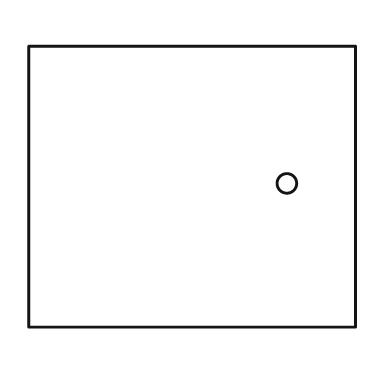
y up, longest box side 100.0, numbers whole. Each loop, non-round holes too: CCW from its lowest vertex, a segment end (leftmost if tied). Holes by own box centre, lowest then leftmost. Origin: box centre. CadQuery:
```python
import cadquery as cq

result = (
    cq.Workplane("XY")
    .moveTo(-50.0, -43.0)
    .lineTo(50.0, -43.0)
    .lineTo(50.0, 43.0)
    .lineTo(-50.0, 43.0)
    .close()
    .moveTo(29.0, 1.0)
    .circle(3.0)
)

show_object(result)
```